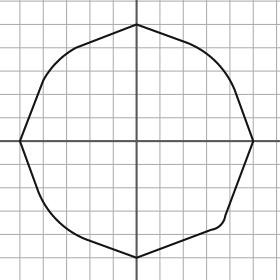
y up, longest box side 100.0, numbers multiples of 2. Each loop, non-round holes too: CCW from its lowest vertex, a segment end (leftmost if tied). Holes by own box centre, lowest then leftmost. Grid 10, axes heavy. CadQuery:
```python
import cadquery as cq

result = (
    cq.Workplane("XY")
    .moveTo(0.0, -50.0)
    .lineTo(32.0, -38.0)
    .threePointArc((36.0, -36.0), (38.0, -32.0))
    .lineTo(50.0, 0.0)
    .lineTo(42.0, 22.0)
    .threePointArc((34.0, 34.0), (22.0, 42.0))
    .lineTo(0.0, 50.0)
    .lineTo(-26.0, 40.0)
    .threePointArc((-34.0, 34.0), (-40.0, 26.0))
    .lineTo(-50.0, 0.0)
    .lineTo(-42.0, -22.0)
    .threePointArc((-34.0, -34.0), (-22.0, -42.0))
    .close()
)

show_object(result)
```